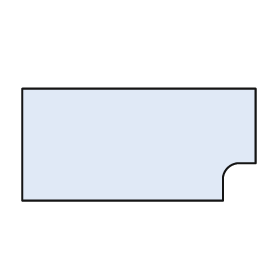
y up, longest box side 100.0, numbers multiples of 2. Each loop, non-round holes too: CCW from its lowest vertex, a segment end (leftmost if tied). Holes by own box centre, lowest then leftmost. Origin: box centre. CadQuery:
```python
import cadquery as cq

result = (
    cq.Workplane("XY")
    .moveTo(-50.0, -24.0)
    .lineTo(36.0, -24.0)
    .lineTo(36.0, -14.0)
    .threePointArc((38.0, -10.0), (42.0, -8.0))
    .lineTo(50.0, -8.0)
    .lineTo(50.0, 24.0)
    .lineTo(-50.0, 24.0)
    .close()
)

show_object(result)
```